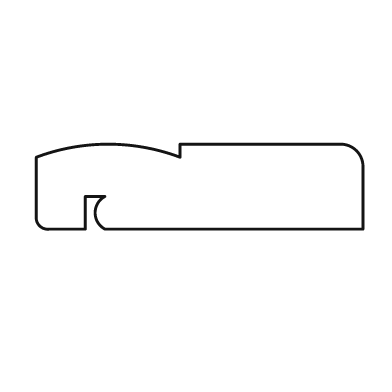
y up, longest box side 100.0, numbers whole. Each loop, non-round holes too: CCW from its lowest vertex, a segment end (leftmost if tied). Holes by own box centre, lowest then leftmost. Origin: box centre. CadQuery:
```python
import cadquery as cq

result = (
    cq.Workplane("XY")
    .moveTo(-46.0, -13.0)
    .lineTo(-35.0, -13.0)
    .lineTo(-35.0, -3.0)
    .lineTo(-29.0, -3.0)
    .threePointArc((-32.0, -8.0), (-29.0, -13.0))
    .lineTo(50.0, -13.0)
    .lineTo(50.0, 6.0)
    .threePointArc((48.0, 11.0), (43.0, 13.0))
    .lineTo(-6.0, 13.0)
    .lineTo(-6.0, 9.0)
    .threePointArc((-28.0, 13.0), (-50.0, 9.0))
    .lineTo(-50.0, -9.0)
    .threePointArc((-49.0, -12.0), (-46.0, -13.0))
    .close()
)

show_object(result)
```